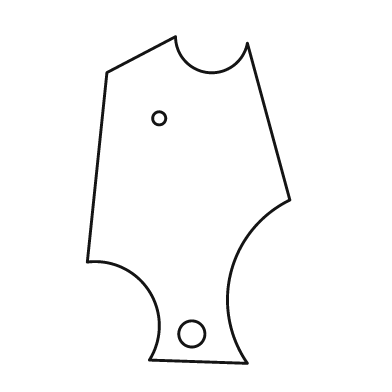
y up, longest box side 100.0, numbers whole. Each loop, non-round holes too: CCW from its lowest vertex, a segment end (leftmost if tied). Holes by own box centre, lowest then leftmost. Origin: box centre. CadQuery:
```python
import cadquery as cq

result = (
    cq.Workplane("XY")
    .moveTo(18.0, -50.0)
    .threePointArc((13.0, -22.0), (31.0, 0.0))
    .lineTo(18.0, 48.0)
    .threePointArc((6.0, 39.0), (-4.0, 50.0))
    .lineTo(-25.0, 39.0)
    .lineTo(-31.0, -19.0)
    .threePointArc((-12.0, -28.0), (-12.0, -49.0))
    .close()
    .moveTo(1.0, -41.0)
    .circle(4.0)
    .moveTo(-9.0, 25.0)
    .circle(2.0)
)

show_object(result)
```